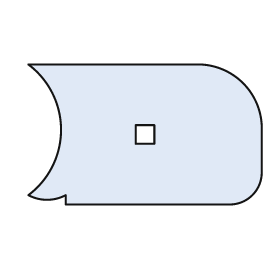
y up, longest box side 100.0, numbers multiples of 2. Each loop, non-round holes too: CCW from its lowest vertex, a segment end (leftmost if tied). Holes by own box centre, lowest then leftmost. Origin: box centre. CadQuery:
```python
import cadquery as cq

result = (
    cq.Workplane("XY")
    .moveTo(-34.0, -30.0)
    .lineTo(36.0, -30.0)
    .threePointArc((46.0, -26.0), (50.0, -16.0))
    .lineTo(50.0, 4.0)
    .threePointArc((42.0, 22.0), (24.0, 30.0))
    .lineTo(-50.0, 30.0)
    .threePointArc((-36.0, 2.0), (-50.0, -26.0))
    .threePointArc((-42.0, -28.0), (-34.0, -26.0))
    .close()
    .moveTo(-4.0, -4.0)
    .lineTo(4.0, -4.0)
    .lineTo(4.0, 4.0)
    .lineTo(-4.0, 4.0)
    .close()
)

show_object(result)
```